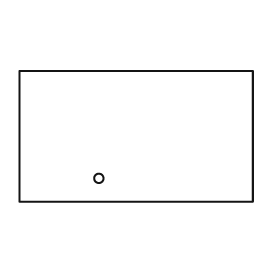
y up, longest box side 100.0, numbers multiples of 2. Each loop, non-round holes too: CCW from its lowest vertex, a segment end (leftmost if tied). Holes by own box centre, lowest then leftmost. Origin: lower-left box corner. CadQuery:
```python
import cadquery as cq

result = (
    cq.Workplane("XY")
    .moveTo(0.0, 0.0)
    .lineTo(100.0, 0.0)
    .lineTo(100.0, 56.0)
    .lineTo(0.0, 56.0)
    .close()
    .moveTo(34.0, 10.0)
    .circle(2.0)
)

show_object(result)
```